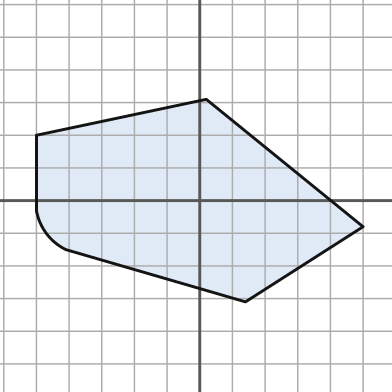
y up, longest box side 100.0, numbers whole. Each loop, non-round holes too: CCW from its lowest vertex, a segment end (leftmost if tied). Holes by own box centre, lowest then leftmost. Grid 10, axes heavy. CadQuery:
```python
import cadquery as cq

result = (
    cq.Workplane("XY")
    .moveTo(14.0, -31.0)
    .lineTo(50.0, -8.0)
    .lineTo(2.0, 31.0)
    .lineTo(-50.0, 20.0)
    .lineTo(-50.0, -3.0)
    .threePointArc((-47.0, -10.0), (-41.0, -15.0))
    .close()
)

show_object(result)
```